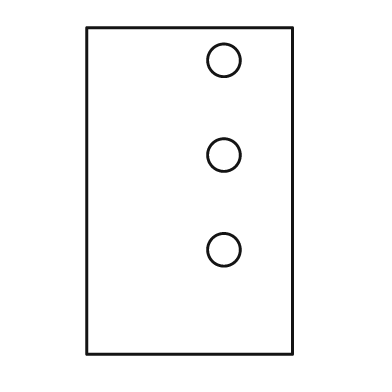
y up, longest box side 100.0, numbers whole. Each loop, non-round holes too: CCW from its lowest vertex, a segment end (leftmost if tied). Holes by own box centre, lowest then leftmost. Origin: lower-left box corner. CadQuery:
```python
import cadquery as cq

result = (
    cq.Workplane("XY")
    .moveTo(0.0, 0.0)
    .lineTo(63.0, 0.0)
    .lineTo(63.0, 100.0)
    .lineTo(0.0, 100.0)
    .close()
    .moveTo(42.0, 32.0)
    .circle(5.0)
    .moveTo(42.0, 61.0)
    .circle(5.0)
    .moveTo(42.0, 90.0)
    .circle(5.0)
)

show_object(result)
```